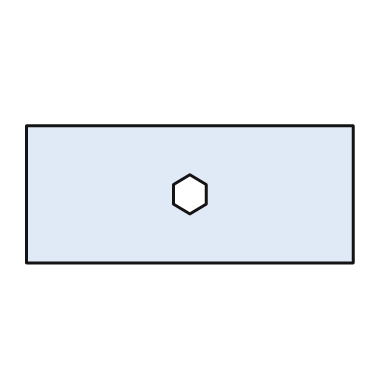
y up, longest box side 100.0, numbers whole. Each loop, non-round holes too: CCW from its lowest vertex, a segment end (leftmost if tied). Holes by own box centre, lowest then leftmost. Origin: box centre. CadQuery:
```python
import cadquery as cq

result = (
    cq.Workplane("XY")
    .moveTo(-50.0, -21.0)
    .lineTo(50.0, -21.0)
    .lineTo(50.0, 21.0)
    .lineTo(-50.0, 21.0)
    .close()
    .moveTo(0.0, -6.0)
    .lineTo(5.0, -3.0)
    .lineTo(5.0, 3.0)
    .lineTo(0.0, 6.0)
    .lineTo(-5.0, 3.0)
    .lineTo(-5.0, -3.0)
    .close()
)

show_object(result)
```